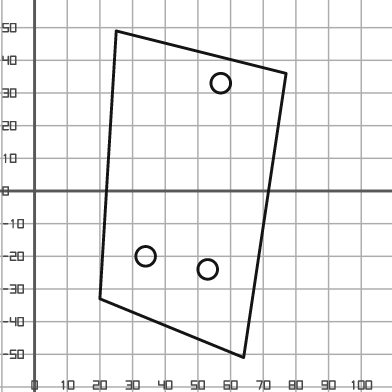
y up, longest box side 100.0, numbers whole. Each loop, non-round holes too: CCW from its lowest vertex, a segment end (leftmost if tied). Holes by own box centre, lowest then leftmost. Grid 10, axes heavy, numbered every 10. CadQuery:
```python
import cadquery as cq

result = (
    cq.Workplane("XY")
    .moveTo(64.0, -51.0)
    .lineTo(77.0, 36.0)
    .lineTo(25.0, 49.0)
    .lineTo(20.0, -33.0)
    .close()
    .moveTo(53.0, -24.0)
    .circle(3.0)
    .moveTo(34.0, -20.0)
    .circle(3.0)
    .moveTo(57.0, 33.0)
    .circle(3.0)
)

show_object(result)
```